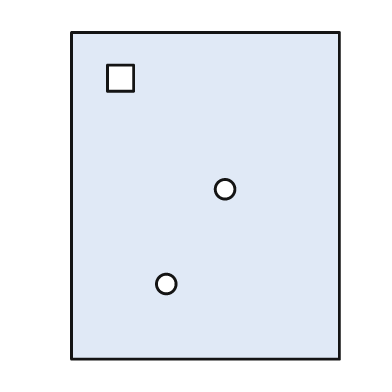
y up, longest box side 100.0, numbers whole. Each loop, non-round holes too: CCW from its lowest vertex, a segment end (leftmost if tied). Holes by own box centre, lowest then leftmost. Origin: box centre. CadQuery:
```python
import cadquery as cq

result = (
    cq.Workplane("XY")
    .moveTo(-41.0, -50.0)
    .lineTo(41.0, -50.0)
    .lineTo(41.0, 50.0)
    .lineTo(-41.0, 50.0)
    .close()
    .moveTo(-12.0, -27.0)
    .circle(3.0)
    .moveTo(6.0, 2.0)
    .circle(3.0)
    .moveTo(-30.0, 32.0)
    .lineTo(-22.0, 32.0)
    .lineTo(-22.0, 40.0)
    .lineTo(-30.0, 40.0)
    .close()
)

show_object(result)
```